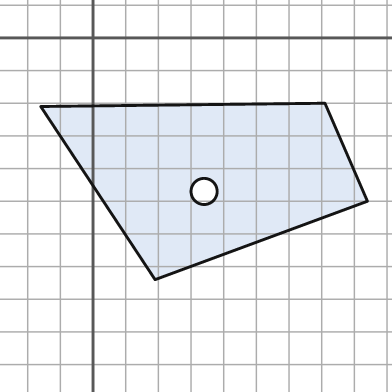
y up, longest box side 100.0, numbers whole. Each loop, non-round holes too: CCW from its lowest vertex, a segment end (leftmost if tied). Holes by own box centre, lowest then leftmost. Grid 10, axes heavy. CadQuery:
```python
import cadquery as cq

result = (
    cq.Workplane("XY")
    .moveTo(19.0, -74.0)
    .lineTo(84.0, -50.0)
    .lineTo(71.0, -20.0)
    .lineTo(-16.0, -21.0)
    .close()
    .moveTo(34.0, -47.0)
    .circle(4.0)
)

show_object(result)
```